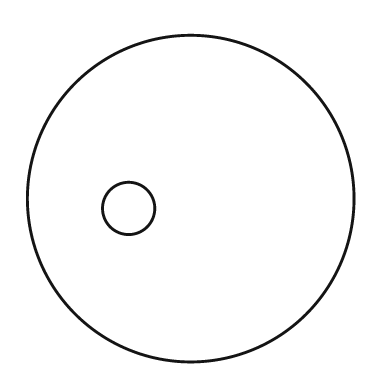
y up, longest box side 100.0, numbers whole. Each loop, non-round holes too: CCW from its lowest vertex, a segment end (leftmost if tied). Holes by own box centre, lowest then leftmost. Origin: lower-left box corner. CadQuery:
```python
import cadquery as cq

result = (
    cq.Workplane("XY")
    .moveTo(50.0, 50.0)
    .circle(50.0)
    .moveTo(31.0, 47.0)
    .circle(8.0)
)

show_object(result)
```